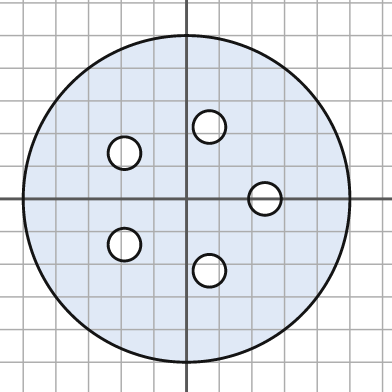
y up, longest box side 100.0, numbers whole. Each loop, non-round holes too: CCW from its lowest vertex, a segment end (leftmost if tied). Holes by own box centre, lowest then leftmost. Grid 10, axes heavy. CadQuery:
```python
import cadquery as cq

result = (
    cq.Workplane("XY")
    .moveTo(0.0, 0.0)
    .circle(50.0)
    .moveTo(7.0, -22.0)
    .circle(5.0)
    .moveTo(-19.0, -14.0)
    .circle(5.0)
    .moveTo(24.0, 0.0)
    .circle(5.0)
    .moveTo(-19.0, 14.0)
    .circle(5.0)
    .moveTo(7.0, 22.0)
    .circle(5.0)
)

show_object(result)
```